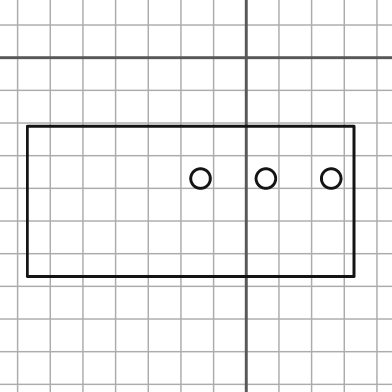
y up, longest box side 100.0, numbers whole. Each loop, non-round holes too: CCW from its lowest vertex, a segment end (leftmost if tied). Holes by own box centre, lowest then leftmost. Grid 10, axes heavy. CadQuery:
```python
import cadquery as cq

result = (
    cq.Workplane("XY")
    .moveTo(-67.0, -67.0)
    .lineTo(33.0, -67.0)
    .lineTo(33.0, -21.0)
    .lineTo(-67.0, -21.0)
    .close()
    .moveTo(-14.0, -37.0)
    .circle(3.0)
    .moveTo(6.0, -37.0)
    .circle(3.0)
    .moveTo(26.0, -37.0)
    .circle(3.0)
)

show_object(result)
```